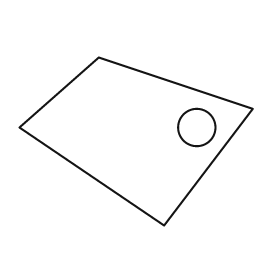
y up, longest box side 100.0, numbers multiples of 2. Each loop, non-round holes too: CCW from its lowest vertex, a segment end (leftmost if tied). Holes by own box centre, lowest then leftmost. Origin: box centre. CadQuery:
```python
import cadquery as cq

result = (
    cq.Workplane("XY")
    .moveTo(12.0, -36.0)
    .lineTo(50.0, 14.0)
    .lineTo(-16.0, 36.0)
    .lineTo(-50.0, 6.0)
    .close()
    .moveTo(26.0, 6.0)
    .circle(8.0)
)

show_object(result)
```